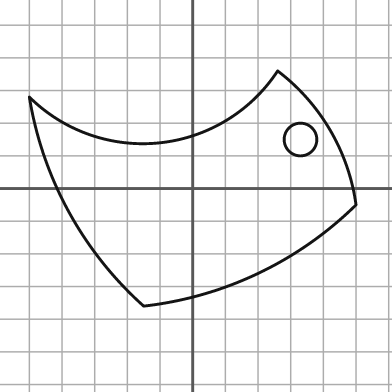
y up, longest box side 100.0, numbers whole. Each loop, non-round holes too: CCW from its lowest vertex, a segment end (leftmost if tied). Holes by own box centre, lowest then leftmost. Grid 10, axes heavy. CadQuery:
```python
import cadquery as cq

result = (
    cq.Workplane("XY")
    .moveTo(-15.0, -36.0)
    .threePointArc((20.0, -26.0), (50.0, -5.0))
    .threePointArc((42.0, 18.0), (26.0, 36.0))
    .threePointArc((-10.0, 14.0), (-50.0, 28.0))
    .threePointArc((-38.0, -7.0), (-15.0, -36.0))
    .close()
    .moveTo(33.0, 15.0)
    .circle(5.0)
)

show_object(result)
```